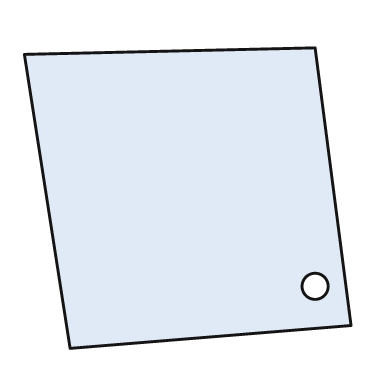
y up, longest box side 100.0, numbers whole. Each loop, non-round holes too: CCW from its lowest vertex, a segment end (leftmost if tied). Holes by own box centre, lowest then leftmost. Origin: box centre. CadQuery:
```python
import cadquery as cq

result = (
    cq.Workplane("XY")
    .moveTo(-36.0, -46.0)
    .lineTo(50.0, -39.0)
    .lineTo(39.0, 46.0)
    .lineTo(-50.0, 44.0)
    .close()
    .moveTo(39.0, -27.0)
    .circle(4.0)
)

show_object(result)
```